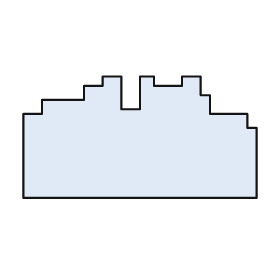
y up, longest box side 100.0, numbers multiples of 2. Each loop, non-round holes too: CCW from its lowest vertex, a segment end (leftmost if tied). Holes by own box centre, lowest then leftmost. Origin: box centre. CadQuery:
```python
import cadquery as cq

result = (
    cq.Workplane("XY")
    .moveTo(-50.0, -26.0)
    .lineTo(50.0, -26.0)
    .lineTo(50.0, 4.0)
    .lineTo(46.0, 4.0)
    .lineTo(46.0, 10.0)
    .lineTo(30.0, 10.0)
    .lineTo(30.0, 18.0)
    .lineTo(26.0, 18.0)
    .lineTo(26.0, 26.0)
    .lineTo(18.0, 26.0)
    .lineTo(18.0, 22.0)
    .lineTo(6.0, 22.0)
    .lineTo(6.0, 26.0)
    .lineTo(0.0, 26.0)
    .lineTo(0.0, 12.0)
    .lineTo(-8.0, 12.0)
    .lineTo(-8.0, 26.0)
    .lineTo(-16.0, 26.0)
    .lineTo(-16.0, 22.0)
    .lineTo(-24.0, 22.0)
    .lineTo(-24.0, 16.0)
    .lineTo(-42.0, 16.0)
    .lineTo(-42.0, 10.0)
    .lineTo(-50.0, 10.0)
    .close()
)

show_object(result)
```